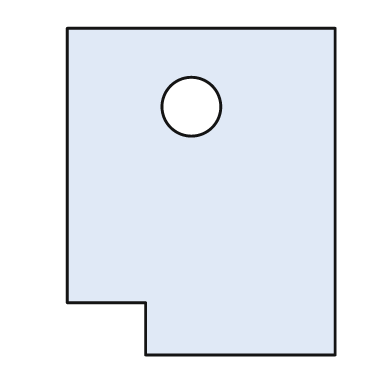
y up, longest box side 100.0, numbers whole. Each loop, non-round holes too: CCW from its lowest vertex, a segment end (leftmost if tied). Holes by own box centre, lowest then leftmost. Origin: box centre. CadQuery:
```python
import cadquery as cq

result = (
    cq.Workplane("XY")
    .moveTo(-17.0, -50.0)
    .lineTo(41.0, -50.0)
    .lineTo(41.0, 50.0)
    .lineTo(-41.0, 50.0)
    .lineTo(-41.0, -34.0)
    .lineTo(-17.0, -34.0)
    .close()
    .moveTo(-3.0, 26.0)
    .circle(9.0)
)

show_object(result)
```